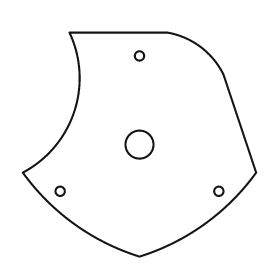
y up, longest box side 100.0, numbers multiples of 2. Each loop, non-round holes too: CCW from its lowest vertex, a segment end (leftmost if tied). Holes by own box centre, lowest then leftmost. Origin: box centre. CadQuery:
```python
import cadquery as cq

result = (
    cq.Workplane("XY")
    .moveTo(0.0, -48.0)
    .threePointArc((28.0, -34.0), (50.0, -12.0))
    .lineTo(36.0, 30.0)
    .threePointArc((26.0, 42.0), (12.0, 48.0))
    .lineTo(-30.0, 48.0)
    .threePointArc((-28.0, 14.0), (-50.0, -12.0))
    .threePointArc((-28.0, -34.0), (0.0, -48.0))
    .close()
    .moveTo(-34.0, -20.0)
    .circle(2.0)
    .moveTo(34.0, -20.0)
    .circle(2.0)
    .moveTo(0.0, 0.0)
    .circle(6.0)
    .moveTo(0.0, 38.0)
    .circle(2.0)
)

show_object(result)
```